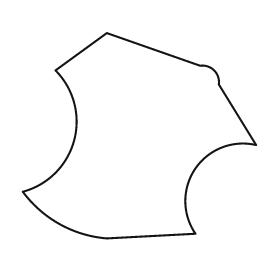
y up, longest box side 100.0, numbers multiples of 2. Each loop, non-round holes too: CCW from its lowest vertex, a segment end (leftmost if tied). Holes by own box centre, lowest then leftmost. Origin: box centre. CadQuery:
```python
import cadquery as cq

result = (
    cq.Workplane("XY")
    .moveTo(-14.0, -44.0)
    .lineTo(24.0, -42.0)
    .threePointArc((24.0, -14.0), (50.0, -4.0))
    .lineTo(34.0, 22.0)
    .threePointArc((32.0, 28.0), (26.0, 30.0))
    .lineTo(-14.0, 44.0)
    .lineTo(-36.0, 28.0)
    .threePointArc((-28.0, -2.0), (-50.0, -24.0))
    .threePointArc((-34.0, -38.0), (-14.0, -44.0))
    .close()
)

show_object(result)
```